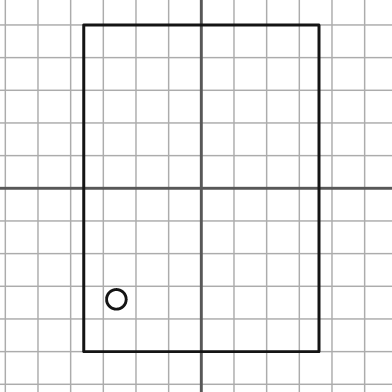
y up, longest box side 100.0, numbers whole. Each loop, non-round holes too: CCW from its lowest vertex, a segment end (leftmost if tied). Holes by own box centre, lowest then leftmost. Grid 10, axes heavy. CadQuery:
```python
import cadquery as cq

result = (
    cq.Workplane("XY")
    .moveTo(-36.0, -50.0)
    .lineTo(36.0, -50.0)
    .lineTo(36.0, 50.0)
    .lineTo(-36.0, 50.0)
    .close()
    .moveTo(-26.0, -34.0)
    .circle(3.0)
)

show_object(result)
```